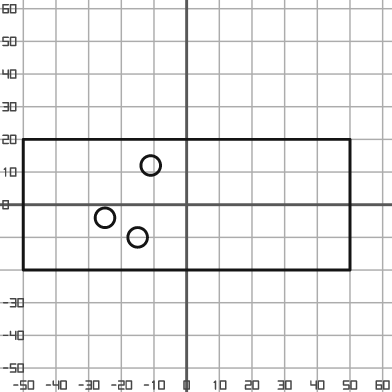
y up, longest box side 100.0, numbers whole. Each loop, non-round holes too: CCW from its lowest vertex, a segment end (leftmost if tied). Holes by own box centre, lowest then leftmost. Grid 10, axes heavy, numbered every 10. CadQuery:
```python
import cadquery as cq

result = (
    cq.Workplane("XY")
    .moveTo(-50.0, -20.0)
    .lineTo(50.0, -20.0)
    .lineTo(50.0, 20.0)
    .lineTo(-50.0, 20.0)
    .close()
    .moveTo(-15.0, -10.0)
    .circle(3.0)
    .moveTo(-25.0, -4.0)
    .circle(3.0)
    .moveTo(-11.0, 12.0)
    .circle(3.0)
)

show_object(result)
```